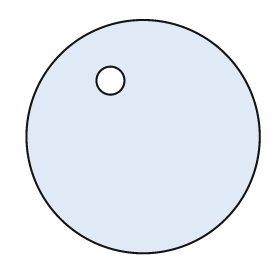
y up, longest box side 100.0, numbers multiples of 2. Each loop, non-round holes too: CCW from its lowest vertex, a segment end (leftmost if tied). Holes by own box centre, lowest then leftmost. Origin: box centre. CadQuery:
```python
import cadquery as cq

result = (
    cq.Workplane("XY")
    .moveTo(0.0, 0.0)
    .circle(50.0)
    .moveTo(-14.0, 24.0)
    .circle(6.0)
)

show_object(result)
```